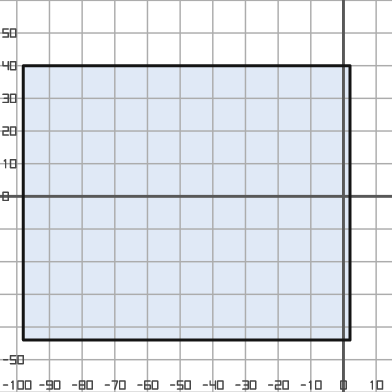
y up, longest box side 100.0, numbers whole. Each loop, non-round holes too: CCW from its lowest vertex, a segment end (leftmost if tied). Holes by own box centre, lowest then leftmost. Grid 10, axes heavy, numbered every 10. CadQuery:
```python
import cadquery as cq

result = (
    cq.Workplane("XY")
    .moveTo(-98.0, -44.0)
    .lineTo(2.0, -44.0)
    .lineTo(2.0, 40.0)
    .lineTo(-98.0, 40.0)
    .close()
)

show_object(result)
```